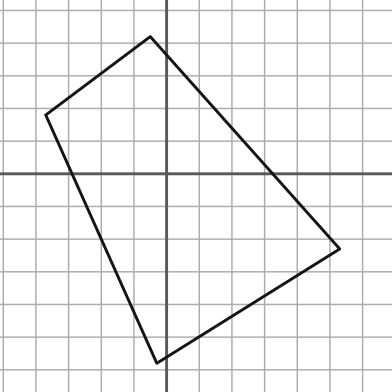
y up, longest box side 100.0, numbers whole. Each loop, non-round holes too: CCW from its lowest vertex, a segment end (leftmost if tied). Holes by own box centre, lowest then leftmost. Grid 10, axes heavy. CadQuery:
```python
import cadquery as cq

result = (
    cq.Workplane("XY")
    .moveTo(-3.0, -58.0)
    .lineTo(53.0, -23.0)
    .lineTo(-5.0, 42.0)
    .lineTo(-37.0, 18.0)
    .close()
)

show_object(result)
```